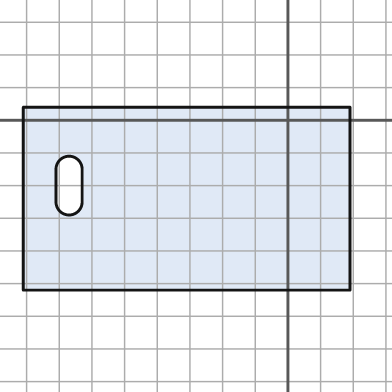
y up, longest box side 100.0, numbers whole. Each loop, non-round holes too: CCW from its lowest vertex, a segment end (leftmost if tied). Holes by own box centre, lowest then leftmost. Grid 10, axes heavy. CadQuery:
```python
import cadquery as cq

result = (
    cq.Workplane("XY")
    .moveTo(-81.0, -52.0)
    .lineTo(19.0, -52.0)
    .lineTo(19.0, 4.0)
    .lineTo(-81.0, 4.0)
    .close()
    .moveTo(-71.0, -25.0)
    .threePointArc((-67.0, -29.0), (-63.0, -25.0))
    .lineTo(-63.0, -15.0)
    .threePointArc((-67.0, -11.0), (-71.0, -15.0))
    .close()
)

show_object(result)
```